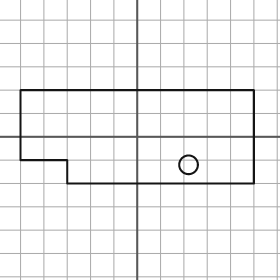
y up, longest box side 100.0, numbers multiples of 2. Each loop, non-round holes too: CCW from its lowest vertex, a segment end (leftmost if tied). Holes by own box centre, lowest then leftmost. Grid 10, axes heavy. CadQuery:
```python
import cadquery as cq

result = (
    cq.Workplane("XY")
    .moveTo(-30.0, -20.0)
    .lineTo(50.0, -20.0)
    .lineTo(50.0, 20.0)
    .lineTo(-50.0, 20.0)
    .lineTo(-50.0, -10.0)
    .lineTo(-30.0, -10.0)
    .close()
    .moveTo(22.0, -12.0)
    .circle(4.0)
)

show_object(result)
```